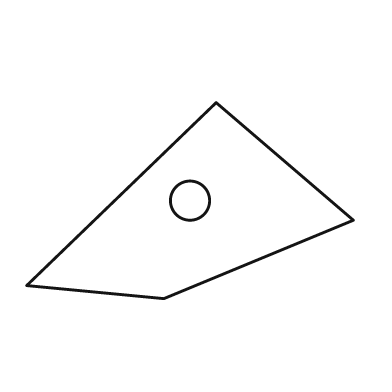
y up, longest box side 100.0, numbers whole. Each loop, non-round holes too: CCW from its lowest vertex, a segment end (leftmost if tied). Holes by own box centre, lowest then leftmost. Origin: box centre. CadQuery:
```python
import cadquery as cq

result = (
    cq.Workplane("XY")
    .moveTo(-8.0, -30.0)
    .lineTo(50.0, -6.0)
    .lineTo(8.0, 30.0)
    .lineTo(-50.0, -26.0)
    .close()
    .moveTo(0.0, 0.0)
    .circle(6.0)
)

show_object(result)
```